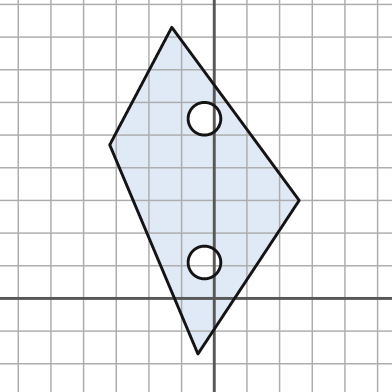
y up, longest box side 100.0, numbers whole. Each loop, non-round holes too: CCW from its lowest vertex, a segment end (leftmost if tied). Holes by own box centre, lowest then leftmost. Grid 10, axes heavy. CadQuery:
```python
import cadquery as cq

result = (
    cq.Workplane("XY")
    .moveTo(-5.0, -17.0)
    .lineTo(26.0, 30.0)
    .lineTo(-13.0, 83.0)
    .lineTo(-32.0, 47.0)
    .close()
    .moveTo(-3.0, 11.0)
    .circle(5.0)
    .moveTo(-3.0, 55.0)
    .circle(5.0)
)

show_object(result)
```